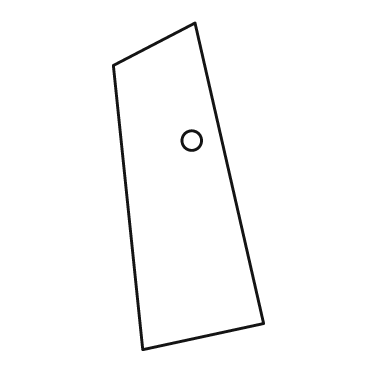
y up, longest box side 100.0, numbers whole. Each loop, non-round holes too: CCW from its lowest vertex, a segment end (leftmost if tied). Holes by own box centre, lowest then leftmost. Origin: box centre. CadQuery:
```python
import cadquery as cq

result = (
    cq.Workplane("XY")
    .moveTo(-14.0, -50.0)
    .lineTo(23.0, -42.0)
    .lineTo(2.0, 50.0)
    .lineTo(-23.0, 37.0)
    .close()
    .moveTo(1.0, 14.0)
    .circle(3.0)
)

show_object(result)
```